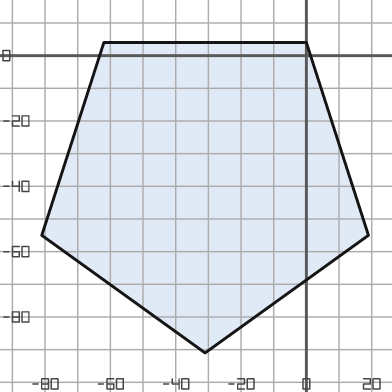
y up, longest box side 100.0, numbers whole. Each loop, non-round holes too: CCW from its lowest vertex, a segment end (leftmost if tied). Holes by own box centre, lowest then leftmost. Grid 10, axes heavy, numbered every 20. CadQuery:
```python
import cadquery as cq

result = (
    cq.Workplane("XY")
    .moveTo(-31.0, -91.0)
    .lineTo(19.0, -55.0)
    .lineTo(0.0, 4.0)
    .lineTo(-62.0, 4.0)
    .lineTo(-81.0, -55.0)
    .close()
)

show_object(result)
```